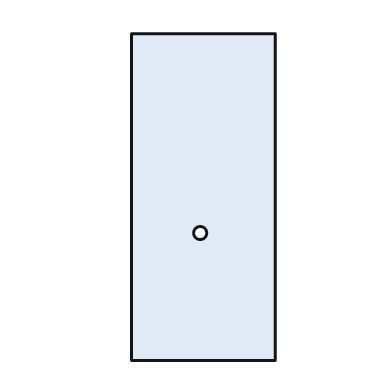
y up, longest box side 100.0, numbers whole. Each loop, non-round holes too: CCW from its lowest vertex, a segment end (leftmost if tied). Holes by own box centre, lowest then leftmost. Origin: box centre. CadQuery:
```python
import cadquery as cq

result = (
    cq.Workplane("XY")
    .moveTo(-22.0, -50.0)
    .lineTo(22.0, -50.0)
    .lineTo(22.0, 50.0)
    .lineTo(-22.0, 50.0)
    .close()
    .moveTo(-1.0, -11.0)
    .circle(2.0)
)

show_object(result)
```